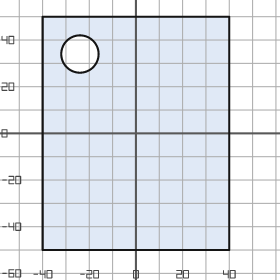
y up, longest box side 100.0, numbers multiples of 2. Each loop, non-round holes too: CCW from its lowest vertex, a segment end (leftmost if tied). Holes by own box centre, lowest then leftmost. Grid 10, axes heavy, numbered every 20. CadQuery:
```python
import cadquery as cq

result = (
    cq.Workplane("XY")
    .moveTo(-40.0, -50.0)
    .lineTo(40.0, -50.0)
    .lineTo(40.0, 50.0)
    .lineTo(-40.0, 50.0)
    .close()
    .moveTo(-24.0, 34.0)
    .circle(8.0)
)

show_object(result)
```